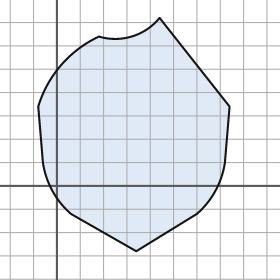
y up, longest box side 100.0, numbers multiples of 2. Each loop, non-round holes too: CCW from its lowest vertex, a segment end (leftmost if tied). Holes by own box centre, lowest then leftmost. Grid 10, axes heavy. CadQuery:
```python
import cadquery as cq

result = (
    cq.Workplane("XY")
    .moveTo(34.0, -28.0)
    .lineTo(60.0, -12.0)
    .threePointArc((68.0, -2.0), (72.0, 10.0))
    .lineTo(74.0, 34.0)
    .lineTo(44.0, 72.0)
    .threePointArc((32.0, 64.0), (18.0, 64.0))
    .threePointArc((2.0, 52.0), (-8.0, 34.0))
    .lineTo(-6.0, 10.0)
    .threePointArc((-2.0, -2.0), (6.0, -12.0))
    .close()
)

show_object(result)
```